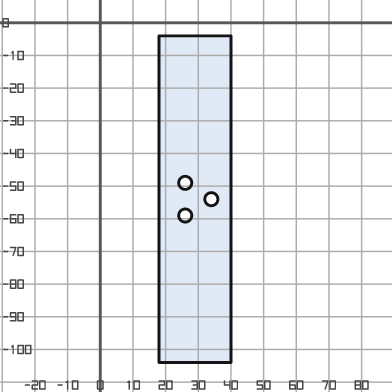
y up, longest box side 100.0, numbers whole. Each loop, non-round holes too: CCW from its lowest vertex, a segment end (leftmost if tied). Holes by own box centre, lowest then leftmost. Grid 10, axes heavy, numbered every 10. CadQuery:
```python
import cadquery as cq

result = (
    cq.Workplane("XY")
    .moveTo(18.0, -104.0)
    .lineTo(40.0, -104.0)
    .lineTo(40.0, -4.0)
    .lineTo(18.0, -4.0)
    .close()
    .moveTo(26.0, -59.0)
    .circle(2.0)
    .moveTo(34.0, -54.0)
    .circle(2.0)
    .moveTo(26.0, -49.0)
    .circle(2.0)
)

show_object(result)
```